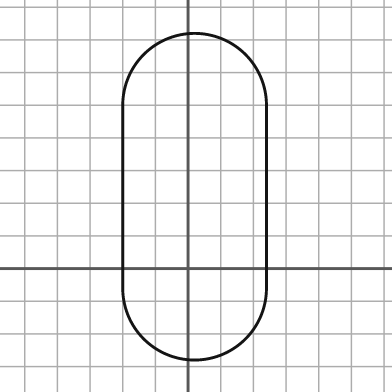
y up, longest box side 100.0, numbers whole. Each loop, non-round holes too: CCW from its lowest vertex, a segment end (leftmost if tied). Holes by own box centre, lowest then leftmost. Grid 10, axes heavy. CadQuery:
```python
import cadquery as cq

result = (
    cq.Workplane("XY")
    .moveTo(-20.0, -6.0)
    .threePointArc((2.0, -28.0), (24.0, -6.0))
    .lineTo(24.0, 50.0)
    .threePointArc((2.0, 72.0), (-20.0, 50.0))
    .close()
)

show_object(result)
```